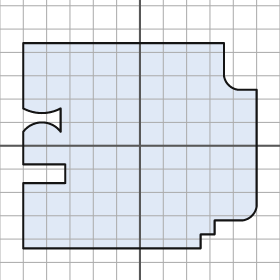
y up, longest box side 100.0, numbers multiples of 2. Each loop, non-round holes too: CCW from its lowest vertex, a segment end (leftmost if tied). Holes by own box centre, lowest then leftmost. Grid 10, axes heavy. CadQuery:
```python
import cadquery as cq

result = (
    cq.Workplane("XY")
    .moveTo(-50.0, -44.0)
    .lineTo(26.0, -44.0)
    .lineTo(26.0, -38.0)
    .lineTo(32.0, -38.0)
    .lineTo(32.0, -32.0)
    .lineTo(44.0, -32.0)
    .threePointArc((48.0, -30.0), (50.0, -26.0))
    .lineTo(50.0, 24.0)
    .lineTo(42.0, 24.0)
    .threePointArc((38.0, 26.0), (36.0, 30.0))
    .lineTo(36.0, 44.0)
    .lineTo(-50.0, 44.0)
    .lineTo(-50.0, 16.0)
    .threePointArc((-42.0, 14.0), (-34.0, 16.0))
    .lineTo(-34.0, 6.0)
    .threePointArc((-42.0, 10.0), (-50.0, 6.0))
    .lineTo(-50.0, -8.0)
    .lineTo(-32.0, -8.0)
    .lineTo(-32.0, -16.0)
    .lineTo(-50.0, -16.0)
    .close()
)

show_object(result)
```